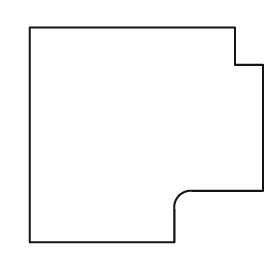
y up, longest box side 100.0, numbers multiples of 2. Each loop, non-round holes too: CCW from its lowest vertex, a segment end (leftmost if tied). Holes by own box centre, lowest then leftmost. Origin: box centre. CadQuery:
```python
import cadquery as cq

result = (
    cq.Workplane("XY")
    .moveTo(-50.0, -46.0)
    .lineTo(12.0, -46.0)
    .lineTo(12.0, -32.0)
    .threePointArc((14.0, -26.0), (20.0, -24.0))
    .lineTo(50.0, -24.0)
    .lineTo(50.0, 30.0)
    .lineTo(38.0, 30.0)
    .lineTo(38.0, 46.0)
    .lineTo(-50.0, 46.0)
    .close()
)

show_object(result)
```